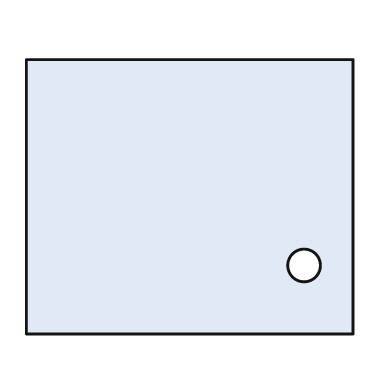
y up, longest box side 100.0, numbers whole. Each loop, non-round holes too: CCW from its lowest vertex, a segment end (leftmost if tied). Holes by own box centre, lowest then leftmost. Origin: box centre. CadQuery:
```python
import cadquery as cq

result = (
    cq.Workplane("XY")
    .moveTo(-50.0, -42.0)
    .lineTo(50.0, -42.0)
    .lineTo(50.0, 42.0)
    .lineTo(-50.0, 42.0)
    .close()
    .moveTo(35.0, -21.0)
    .circle(5.0)
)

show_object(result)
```